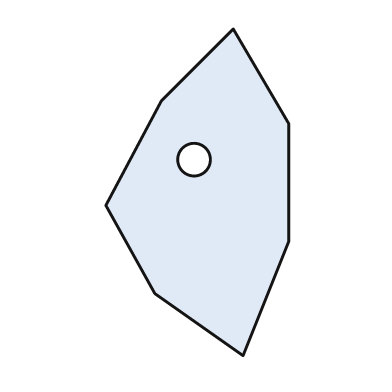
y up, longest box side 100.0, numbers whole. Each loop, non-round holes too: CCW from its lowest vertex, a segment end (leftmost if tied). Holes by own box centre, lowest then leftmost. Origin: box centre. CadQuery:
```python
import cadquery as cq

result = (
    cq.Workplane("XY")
    .moveTo(14.0, -50.0)
    .lineTo(28.0, -15.0)
    .lineTo(28.0, 21.0)
    .lineTo(11.0, 50.0)
    .lineTo(-11.0, 28.0)
    .lineTo(-28.0, -4.0)
    .lineTo(-13.0, -31.0)
    .close()
    .moveTo(-1.0, 10.0)
    .circle(5.0)
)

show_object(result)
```